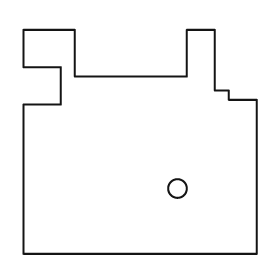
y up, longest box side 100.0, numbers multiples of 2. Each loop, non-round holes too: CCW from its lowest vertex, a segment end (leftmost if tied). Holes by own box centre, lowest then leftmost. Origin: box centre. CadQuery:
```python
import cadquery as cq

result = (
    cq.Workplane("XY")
    .moveTo(-50.0, -48.0)
    .lineTo(50.0, -48.0)
    .lineTo(50.0, 18.0)
    .lineTo(38.0, 18.0)
    .lineTo(38.0, 22.0)
    .lineTo(32.0, 22.0)
    .lineTo(32.0, 48.0)
    .lineTo(20.0, 48.0)
    .lineTo(20.0, 28.0)
    .lineTo(-28.0, 28.0)
    .lineTo(-28.0, 48.0)
    .lineTo(-50.0, 48.0)
    .lineTo(-50.0, 32.0)
    .lineTo(-34.0, 32.0)
    .lineTo(-34.0, 16.0)
    .lineTo(-50.0, 16.0)
    .close()
    .moveTo(16.0, -20.0)
    .circle(4.0)
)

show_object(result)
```